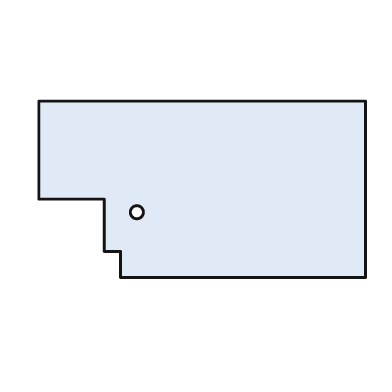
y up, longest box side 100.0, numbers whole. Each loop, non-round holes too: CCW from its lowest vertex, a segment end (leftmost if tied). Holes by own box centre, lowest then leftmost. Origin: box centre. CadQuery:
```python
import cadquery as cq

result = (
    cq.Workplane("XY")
    .moveTo(-25.0, -27.0)
    .lineTo(50.0, -27.0)
    .lineTo(50.0, 27.0)
    .lineTo(-50.0, 27.0)
    .lineTo(-50.0, -3.0)
    .lineTo(-30.0, -3.0)
    .lineTo(-30.0, -19.0)
    .lineTo(-25.0, -19.0)
    .close()
    .moveTo(-20.0, -7.0)
    .circle(2.0)
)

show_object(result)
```